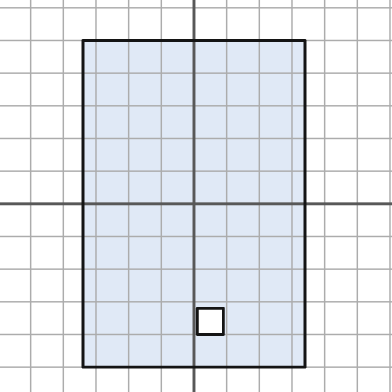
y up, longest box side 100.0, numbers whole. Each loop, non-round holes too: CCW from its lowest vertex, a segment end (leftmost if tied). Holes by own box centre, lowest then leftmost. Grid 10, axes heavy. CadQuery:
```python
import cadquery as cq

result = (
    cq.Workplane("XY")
    .moveTo(-34.0, -50.0)
    .lineTo(34.0, -50.0)
    .lineTo(34.0, 50.0)
    .lineTo(-34.0, 50.0)
    .close()
    .moveTo(1.0, -40.0)
    .lineTo(9.0, -40.0)
    .lineTo(9.0, -32.0)
    .lineTo(1.0, -32.0)
    .close()
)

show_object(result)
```